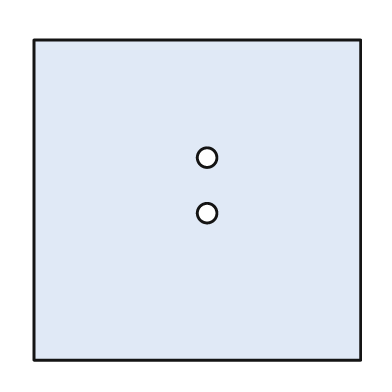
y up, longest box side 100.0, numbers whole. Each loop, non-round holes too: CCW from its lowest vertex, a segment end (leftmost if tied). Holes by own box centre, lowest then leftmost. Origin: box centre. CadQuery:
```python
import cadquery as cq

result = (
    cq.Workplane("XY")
    .moveTo(-50.0, -49.0)
    .lineTo(50.0, -49.0)
    .lineTo(50.0, 49.0)
    .lineTo(-50.0, 49.0)
    .close()
    .moveTo(3.0, -4.0)
    .circle(3.0)
    .moveTo(3.0, 13.0)
    .circle(3.0)
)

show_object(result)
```